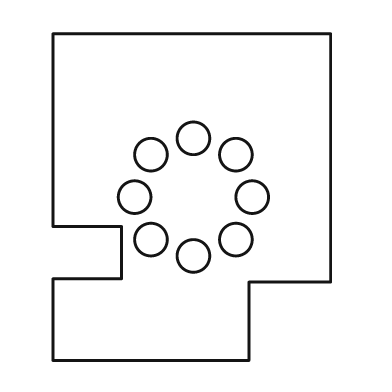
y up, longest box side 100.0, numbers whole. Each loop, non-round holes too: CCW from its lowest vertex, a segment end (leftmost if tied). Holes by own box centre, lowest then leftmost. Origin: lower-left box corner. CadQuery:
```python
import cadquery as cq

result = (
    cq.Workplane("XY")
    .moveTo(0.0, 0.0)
    .lineTo(60.0, 0.0)
    .lineTo(60.0, 24.0)
    .lineTo(85.0, 24.0)
    .lineTo(85.0, 100.0)
    .lineTo(0.0, 100.0)
    .lineTo(0.0, 41.0)
    .lineTo(21.0, 41.0)
    .lineTo(21.0, 25.0)
    .lineTo(0.0, 25.0)
    .close()
    .moveTo(43.0, 32.0)
    .circle(5.0)
    .moveTo(30.0, 37.0)
    .circle(5.0)
    .moveTo(56.0, 37.0)
    .circle(5.0)
    .moveTo(25.0, 50.0)
    .circle(5.0)
    .moveTo(61.0, 50.0)
    .circle(5.0)
    .moveTo(30.0, 63.0)
    .circle(5.0)
    .moveTo(56.0, 63.0)
    .circle(5.0)
    .moveTo(43.0, 68.0)
    .circle(5.0)
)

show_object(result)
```